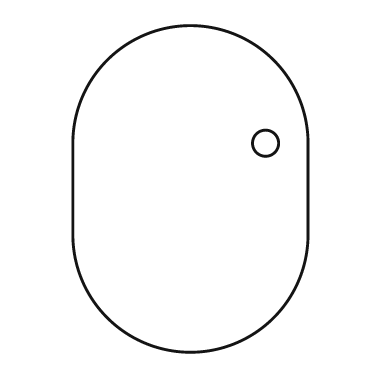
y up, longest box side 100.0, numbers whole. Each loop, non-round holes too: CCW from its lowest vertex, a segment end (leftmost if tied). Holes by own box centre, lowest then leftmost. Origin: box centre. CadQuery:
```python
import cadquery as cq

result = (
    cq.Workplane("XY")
    .moveTo(-36.0, -14.0)
    .threePointArc((0.0, -50.0), (36.0, -14.0))
    .lineTo(36.0, 14.0)
    .threePointArc((0.0, 50.0), (-36.0, 14.0))
    .close()
    .moveTo(23.0, 14.0)
    .circle(4.0)
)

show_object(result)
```